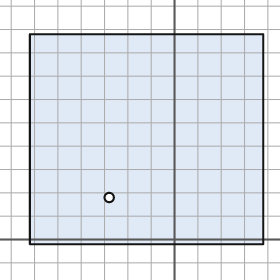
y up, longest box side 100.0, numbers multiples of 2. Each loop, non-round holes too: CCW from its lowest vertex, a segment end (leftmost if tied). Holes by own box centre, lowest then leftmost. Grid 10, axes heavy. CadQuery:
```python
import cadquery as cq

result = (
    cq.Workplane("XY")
    .moveTo(-62.0, -2.0)
    .lineTo(38.0, -2.0)
    .lineTo(38.0, 88.0)
    .lineTo(-62.0, 88.0)
    .close()
    .moveTo(-28.0, 18.0)
    .circle(2.0)
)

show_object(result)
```